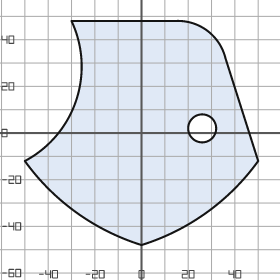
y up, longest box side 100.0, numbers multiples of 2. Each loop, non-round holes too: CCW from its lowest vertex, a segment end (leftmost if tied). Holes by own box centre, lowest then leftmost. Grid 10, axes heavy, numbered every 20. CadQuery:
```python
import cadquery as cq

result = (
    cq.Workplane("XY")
    .moveTo(0.0, -48.0)
    .threePointArc((28.0, -34.0), (50.0, -12.0))
    .lineTo(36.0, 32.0)
    .threePointArc((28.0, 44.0), (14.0, 48.0))
    .lineTo(-30.0, 48.0)
    .threePointArc((-28.0, 14.0), (-50.0, -12.0))
    .threePointArc((-28.0, -34.0), (0.0, -48.0))
    .close()
    .moveTo(26.0, 2.0)
    .circle(6.0)
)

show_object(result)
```